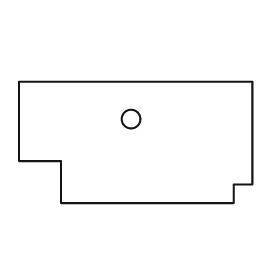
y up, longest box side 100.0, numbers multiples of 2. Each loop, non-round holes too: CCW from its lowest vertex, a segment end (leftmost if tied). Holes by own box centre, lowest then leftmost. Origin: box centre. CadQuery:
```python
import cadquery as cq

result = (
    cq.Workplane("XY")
    .moveTo(-32.0, -26.0)
    .lineTo(42.0, -26.0)
    .lineTo(42.0, -18.0)
    .lineTo(50.0, -18.0)
    .lineTo(50.0, 26.0)
    .lineTo(-50.0, 26.0)
    .lineTo(-50.0, -8.0)
    .lineTo(-32.0, -8.0)
    .close()
    .moveTo(-2.0, 10.0)
    .circle(4.0)
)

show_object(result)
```